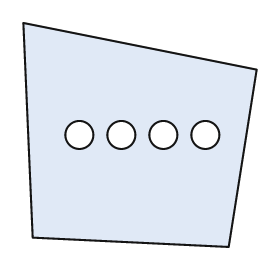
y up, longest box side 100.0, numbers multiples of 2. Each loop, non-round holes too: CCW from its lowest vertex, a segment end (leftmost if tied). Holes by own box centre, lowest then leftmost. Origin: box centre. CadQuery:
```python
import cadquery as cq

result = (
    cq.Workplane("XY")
    .moveTo(38.0, -48.0)
    .lineTo(50.0, 28.0)
    .lineTo(-50.0, 48.0)
    .lineTo(-46.0, -44.0)
    .close()
    .moveTo(-26.0, 0.0)
    .circle(6.0)
    .moveTo(-8.0, 0.0)
    .circle(6.0)
    .moveTo(10.0, 0.0)
    .circle(6.0)
    .moveTo(28.0, 0.0)
    .circle(6.0)
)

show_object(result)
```